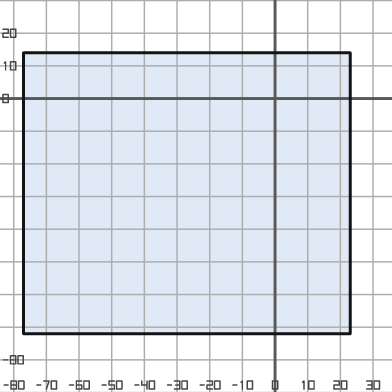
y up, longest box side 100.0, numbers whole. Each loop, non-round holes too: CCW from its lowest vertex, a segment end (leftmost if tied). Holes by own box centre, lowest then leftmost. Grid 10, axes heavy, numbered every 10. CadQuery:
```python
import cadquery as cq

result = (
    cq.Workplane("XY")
    .moveTo(-77.0, -72.0)
    .lineTo(23.0, -72.0)
    .lineTo(23.0, 14.0)
    .lineTo(-77.0, 14.0)
    .close()
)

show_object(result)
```